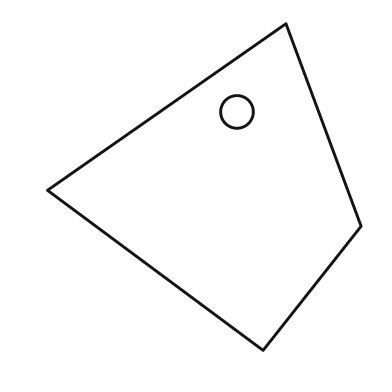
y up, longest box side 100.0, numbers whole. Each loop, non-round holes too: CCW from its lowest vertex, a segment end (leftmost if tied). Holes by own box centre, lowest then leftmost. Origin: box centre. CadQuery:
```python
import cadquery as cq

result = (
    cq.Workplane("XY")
    .moveTo(18.0, -50.0)
    .lineTo(48.0, -12.0)
    .lineTo(25.0, 50.0)
    .lineTo(-48.0, -1.0)
    .close()
    .moveTo(10.0, 23.0)
    .circle(5.0)
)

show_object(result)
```